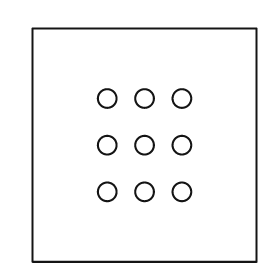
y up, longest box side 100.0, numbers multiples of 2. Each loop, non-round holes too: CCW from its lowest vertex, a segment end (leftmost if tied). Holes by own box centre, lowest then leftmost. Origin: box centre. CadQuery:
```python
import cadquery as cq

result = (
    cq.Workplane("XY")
    .moveTo(-48.0, -50.0)
    .lineTo(48.0, -50.0)
    .lineTo(48.0, 50.0)
    .lineTo(-48.0, 50.0)
    .close()
    .moveTo(-16.0, -20.0)
    .circle(4.0)
    .moveTo(0.0, -20.0)
    .circle(4.0)
    .moveTo(16.0, -20.0)
    .circle(4.0)
    .moveTo(-16.0, 0.0)
    .circle(4.0)
    .moveTo(0.0, 0.0)
    .circle(4.0)
    .moveTo(16.0, 0.0)
    .circle(4.0)
    .moveTo(-16.0, 20.0)
    .circle(4.0)
    .moveTo(0.0, 20.0)
    .circle(4.0)
    .moveTo(16.0, 20.0)
    .circle(4.0)
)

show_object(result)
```